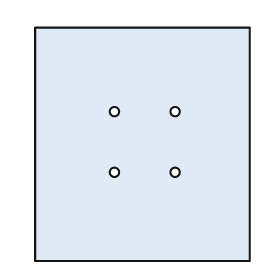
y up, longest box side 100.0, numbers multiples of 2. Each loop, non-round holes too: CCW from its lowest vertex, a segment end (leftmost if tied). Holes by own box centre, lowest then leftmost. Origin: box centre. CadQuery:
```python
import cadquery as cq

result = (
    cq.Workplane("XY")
    .moveTo(-46.0, -50.0)
    .lineTo(46.0, -50.0)
    .lineTo(46.0, 50.0)
    .lineTo(-46.0, 50.0)
    .close()
    .moveTo(-12.0, -12.0)
    .circle(2.0)
    .moveTo(14.0, -12.0)
    .circle(2.0)
    .moveTo(-12.0, 14.0)
    .circle(2.0)
    .moveTo(14.0, 14.0)
    .circle(2.0)
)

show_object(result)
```